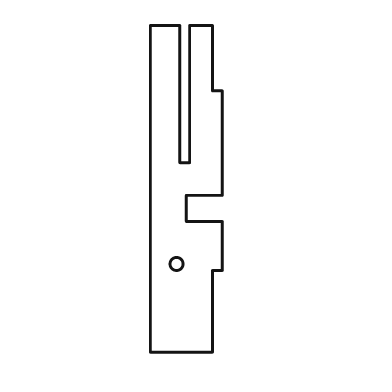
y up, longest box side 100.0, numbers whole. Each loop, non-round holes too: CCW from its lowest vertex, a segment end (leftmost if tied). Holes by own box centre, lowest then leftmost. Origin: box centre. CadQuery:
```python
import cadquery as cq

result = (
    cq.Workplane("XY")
    .moveTo(-11.0, -50.0)
    .lineTo(8.0, -50.0)
    .lineTo(8.0, -25.0)
    .lineTo(11.0, -25.0)
    .lineTo(11.0, -10.0)
    .lineTo(0.0, -10.0)
    .lineTo(0.0, -2.0)
    .lineTo(11.0, -2.0)
    .lineTo(11.0, 30.0)
    .lineTo(8.0, 30.0)
    .lineTo(8.0, 50.0)
    .lineTo(1.0, 50.0)
    .lineTo(1.0, 8.0)
    .lineTo(-2.0, 8.0)
    .lineTo(-2.0, 50.0)
    .lineTo(-11.0, 50.0)
    .close()
    .moveTo(-3.0, -23.0)
    .circle(2.0)
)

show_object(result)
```